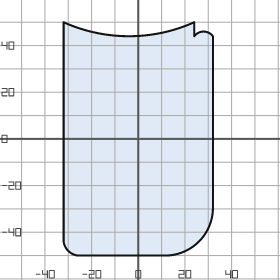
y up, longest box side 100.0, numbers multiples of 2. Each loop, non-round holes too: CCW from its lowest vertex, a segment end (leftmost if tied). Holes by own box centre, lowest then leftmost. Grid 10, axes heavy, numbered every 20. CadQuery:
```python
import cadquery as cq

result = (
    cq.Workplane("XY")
    .moveTo(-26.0, -50.0)
    .lineTo(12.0, -50.0)
    .threePointArc((26.0, -44.0), (32.0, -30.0))
    .lineTo(32.0, 44.0)
    .threePointArc((28.0, 46.0), (24.0, 44.0))
    .lineTo(24.0, 50.0)
    .threePointArc((-4.0, 44.0), (-32.0, 50.0))
    .lineTo(-32.0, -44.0)
    .threePointArc((-30.0, -48.0), (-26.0, -50.0))
    .close()
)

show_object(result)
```